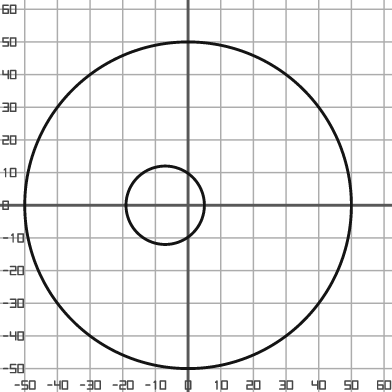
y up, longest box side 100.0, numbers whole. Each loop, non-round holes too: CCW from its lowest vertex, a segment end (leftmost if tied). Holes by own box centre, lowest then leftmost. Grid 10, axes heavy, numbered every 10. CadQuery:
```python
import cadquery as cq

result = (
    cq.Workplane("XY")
    .moveTo(0.0, 0.0)
    .circle(50.0)
    .moveTo(-7.0, 0.0)
    .circle(12.0)
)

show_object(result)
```